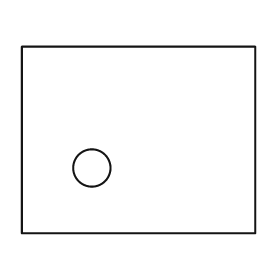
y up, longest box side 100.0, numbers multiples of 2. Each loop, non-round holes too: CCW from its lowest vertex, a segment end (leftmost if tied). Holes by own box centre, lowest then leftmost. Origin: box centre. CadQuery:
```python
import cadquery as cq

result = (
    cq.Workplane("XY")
    .moveTo(-50.0, -40.0)
    .lineTo(50.0, -40.0)
    .lineTo(50.0, 40.0)
    .lineTo(-50.0, 40.0)
    .close()
    .moveTo(-20.0, -12.0)
    .circle(8.0)
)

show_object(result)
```